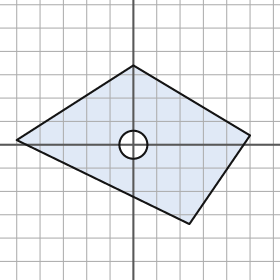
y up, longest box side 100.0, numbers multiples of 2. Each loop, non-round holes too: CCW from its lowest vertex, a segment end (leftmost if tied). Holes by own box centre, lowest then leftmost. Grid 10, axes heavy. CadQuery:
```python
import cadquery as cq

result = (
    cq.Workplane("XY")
    .moveTo(24.0, -34.0)
    .lineTo(50.0, 4.0)
    .lineTo(0.0, 34.0)
    .lineTo(-50.0, 2.0)
    .close()
    .moveTo(0.0, 0.0)
    .circle(6.0)
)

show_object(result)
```